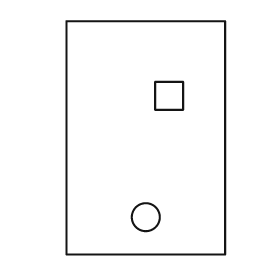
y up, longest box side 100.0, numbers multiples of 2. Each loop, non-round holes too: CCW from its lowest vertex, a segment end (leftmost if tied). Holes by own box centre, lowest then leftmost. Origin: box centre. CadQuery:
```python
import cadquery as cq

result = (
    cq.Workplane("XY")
    .moveTo(-34.0, -50.0)
    .lineTo(34.0, -50.0)
    .lineTo(34.0, 50.0)
    .lineTo(-34.0, 50.0)
    .close()
    .moveTo(0.0, -34.0)
    .circle(6.0)
    .moveTo(4.0, 12.0)
    .lineTo(16.0, 12.0)
    .lineTo(16.0, 24.0)
    .lineTo(4.0, 24.0)
    .close()
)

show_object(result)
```